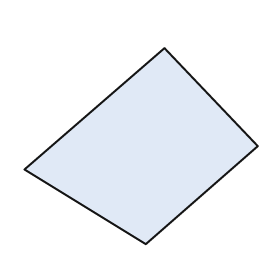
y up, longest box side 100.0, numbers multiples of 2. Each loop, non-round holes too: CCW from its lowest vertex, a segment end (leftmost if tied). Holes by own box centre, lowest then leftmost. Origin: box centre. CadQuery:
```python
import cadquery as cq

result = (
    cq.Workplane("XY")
    .moveTo(2.0, -42.0)
    .lineTo(50.0, 0.0)
    .lineTo(10.0, 42.0)
    .lineTo(-50.0, -10.0)
    .close()
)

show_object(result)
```